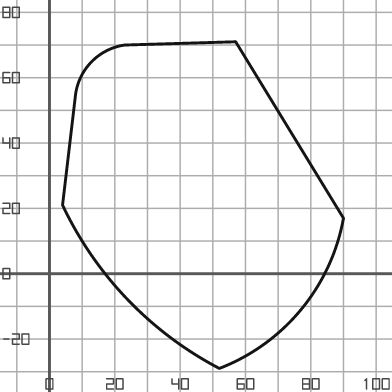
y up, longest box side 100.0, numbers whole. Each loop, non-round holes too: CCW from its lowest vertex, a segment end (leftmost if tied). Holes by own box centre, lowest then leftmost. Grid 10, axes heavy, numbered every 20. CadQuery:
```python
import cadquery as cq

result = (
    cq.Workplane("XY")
    .moveTo(52.0, -29.0)
    .threePointArc((77.0, -11.0), (90.0, 17.0))
    .lineTo(57.0, 71.0)
    .lineTo(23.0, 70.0)
    .threePointArc((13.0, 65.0), (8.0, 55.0))
    .lineTo(4.0, 21.0)
    .threePointArc((24.0, -8.0), (52.0, -29.0))
    .close()
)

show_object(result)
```